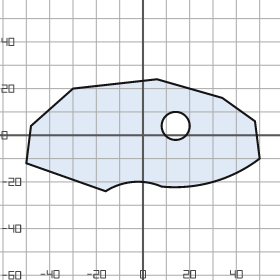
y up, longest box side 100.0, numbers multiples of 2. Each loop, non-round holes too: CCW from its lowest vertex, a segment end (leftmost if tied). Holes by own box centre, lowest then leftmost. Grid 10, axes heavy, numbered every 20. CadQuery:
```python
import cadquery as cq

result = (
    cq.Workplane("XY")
    .moveTo(-16.0, -24.0)
    .threePointArc((-4.0, -20.0), (8.0, -22.0))
    .threePointArc((30.0, -20.0), (50.0, -10.0))
    .lineTo(48.0, 6.0)
    .lineTo(34.0, 16.0)
    .lineTo(6.0, 24.0)
    .lineTo(-30.0, 20.0)
    .lineTo(-48.0, 4.0)
    .lineTo(-50.0, -12.0)
    .close()
    .moveTo(14.0, 4.0)
    .circle(6.0)
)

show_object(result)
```